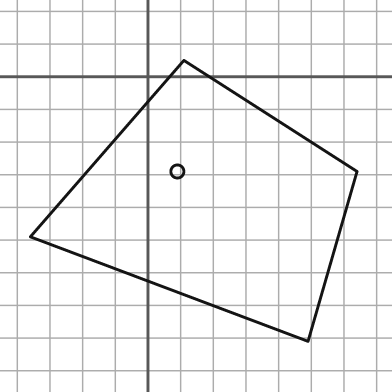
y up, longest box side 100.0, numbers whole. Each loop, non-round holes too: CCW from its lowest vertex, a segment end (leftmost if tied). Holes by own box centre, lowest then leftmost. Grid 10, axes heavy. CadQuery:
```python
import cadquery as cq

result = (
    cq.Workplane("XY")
    .moveTo(49.0, -81.0)
    .lineTo(64.0, -29.0)
    .lineTo(11.0, 5.0)
    .lineTo(-36.0, -49.0)
    .close()
    .moveTo(9.0, -29.0)
    .circle(2.0)
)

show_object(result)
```